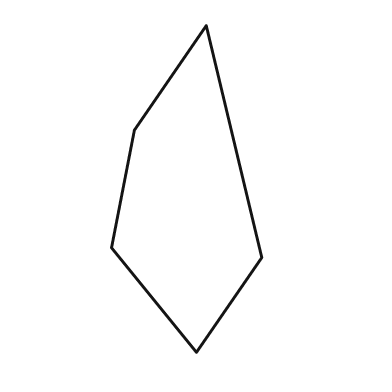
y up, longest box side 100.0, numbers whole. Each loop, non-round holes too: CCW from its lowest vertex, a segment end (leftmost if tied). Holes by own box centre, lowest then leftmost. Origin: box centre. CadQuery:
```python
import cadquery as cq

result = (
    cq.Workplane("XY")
    .moveTo(3.0, -50.0)
    .lineTo(23.0, -21.0)
    .lineTo(6.0, 50.0)
    .lineTo(-16.0, 18.0)
    .lineTo(-23.0, -18.0)
    .close()
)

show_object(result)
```